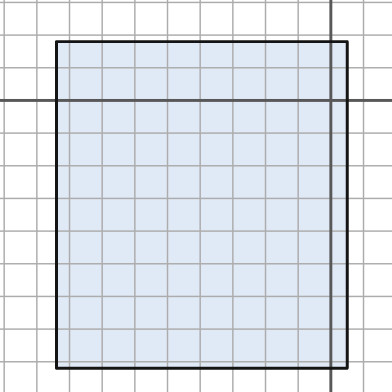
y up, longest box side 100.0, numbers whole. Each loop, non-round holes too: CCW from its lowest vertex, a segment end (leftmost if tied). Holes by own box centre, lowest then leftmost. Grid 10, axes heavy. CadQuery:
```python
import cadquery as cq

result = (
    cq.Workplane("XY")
    .moveTo(-84.0, -82.0)
    .lineTo(5.0, -82.0)
    .lineTo(5.0, 18.0)
    .lineTo(-84.0, 18.0)
    .close()
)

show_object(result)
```